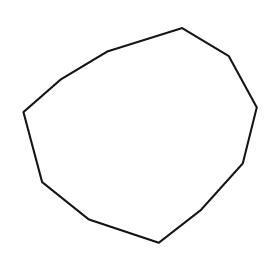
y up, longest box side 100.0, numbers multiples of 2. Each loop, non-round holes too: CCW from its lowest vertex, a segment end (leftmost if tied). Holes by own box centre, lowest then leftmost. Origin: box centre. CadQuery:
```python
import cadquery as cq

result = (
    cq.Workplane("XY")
    .moveTo(8.0, -46.0)
    .lineTo(26.0, -32.0)
    .lineTo(44.0, -12.0)
    .lineTo(50.0, 12.0)
    .lineTo(38.0, 34.0)
    .lineTo(18.0, 46.0)
    .lineTo(-14.0, 36.0)
    .lineTo(-34.0, 24.0)
    .lineTo(-50.0, 10.0)
    .lineTo(-42.0, -20.0)
    .lineTo(-22.0, -36.0)
    .close()
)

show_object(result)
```